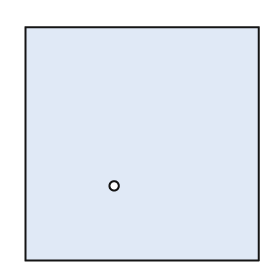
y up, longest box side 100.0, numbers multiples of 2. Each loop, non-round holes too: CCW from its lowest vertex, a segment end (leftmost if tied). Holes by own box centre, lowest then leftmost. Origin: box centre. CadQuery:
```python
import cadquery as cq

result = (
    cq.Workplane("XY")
    .moveTo(-50.0, -50.0)
    .lineTo(50.0, -50.0)
    .lineTo(50.0, 50.0)
    .lineTo(-50.0, 50.0)
    .close()
    .moveTo(-12.0, -18.0)
    .circle(2.0)
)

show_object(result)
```